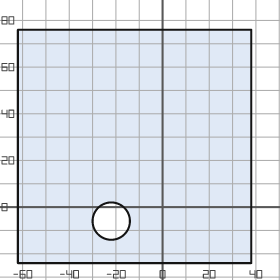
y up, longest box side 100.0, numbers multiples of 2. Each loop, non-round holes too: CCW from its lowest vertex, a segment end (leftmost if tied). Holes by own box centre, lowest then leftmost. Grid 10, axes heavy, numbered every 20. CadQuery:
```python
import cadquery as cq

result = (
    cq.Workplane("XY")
    .moveTo(-62.0, -24.0)
    .lineTo(38.0, -24.0)
    .lineTo(38.0, 76.0)
    .lineTo(-62.0, 76.0)
    .close()
    .moveTo(-22.0, -6.0)
    .circle(8.0)
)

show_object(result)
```